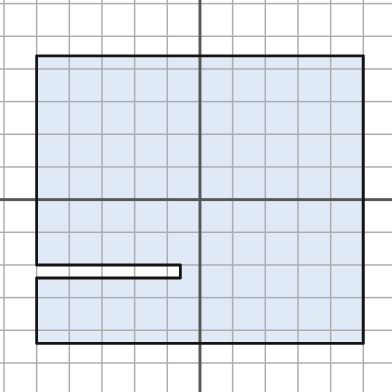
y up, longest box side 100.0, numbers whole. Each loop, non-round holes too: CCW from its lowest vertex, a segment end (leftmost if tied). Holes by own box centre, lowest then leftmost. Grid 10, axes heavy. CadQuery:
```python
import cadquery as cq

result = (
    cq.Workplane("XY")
    .moveTo(-50.0, -44.0)
    .lineTo(50.0, -44.0)
    .lineTo(50.0, 44.0)
    .lineTo(-50.0, 44.0)
    .lineTo(-50.0, -20.0)
    .lineTo(-6.0, -20.0)
    .lineTo(-6.0, -24.0)
    .lineTo(-50.0, -24.0)
    .close()
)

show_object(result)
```